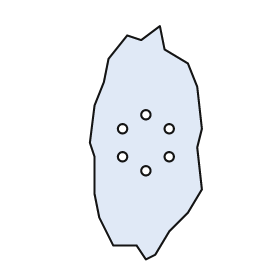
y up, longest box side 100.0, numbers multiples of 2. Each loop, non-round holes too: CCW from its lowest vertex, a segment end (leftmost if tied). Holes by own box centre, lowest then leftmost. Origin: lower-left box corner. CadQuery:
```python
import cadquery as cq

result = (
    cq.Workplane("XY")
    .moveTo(24.0, 0.0)
    .lineTo(28.0, 2.0)
    .lineTo(34.0, 12.0)
    .lineTo(42.0, 20.0)
    .lineTo(48.0, 30.0)
    .lineTo(46.0, 48.0)
    .lineTo(48.0, 56.0)
    .lineTo(46.0, 74.0)
    .lineTo(42.0, 84.0)
    .lineTo(32.0, 90.0)
    .lineTo(30.0, 100.0)
    .lineTo(22.0, 94.0)
    .lineTo(16.0, 96.0)
    .lineTo(8.0, 86.0)
    .lineTo(6.0, 76.0)
    .lineTo(2.0, 66.0)
    .lineTo(0.0, 50.0)
    .lineTo(2.0, 44.0)
    .lineTo(2.0, 28.0)
    .lineTo(4.0, 18.0)
    .lineTo(10.0, 6.0)
    .lineTo(20.0, 6.0)
    .close()
    .moveTo(24.0, 38.0)
    .circle(2.0)
    .moveTo(14.0, 44.0)
    .circle(2.0)
    .moveTo(34.0, 44.0)
    .circle(2.0)
    .moveTo(14.0, 56.0)
    .circle(2.0)
    .moveTo(34.0, 56.0)
    .circle(2.0)
    .moveTo(24.0, 62.0)
    .circle(2.0)
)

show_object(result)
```